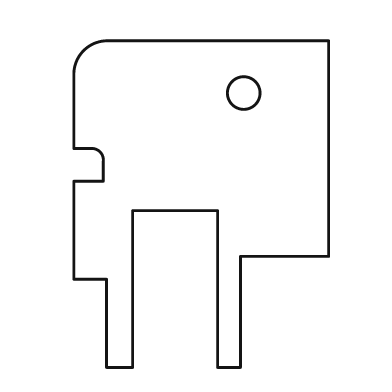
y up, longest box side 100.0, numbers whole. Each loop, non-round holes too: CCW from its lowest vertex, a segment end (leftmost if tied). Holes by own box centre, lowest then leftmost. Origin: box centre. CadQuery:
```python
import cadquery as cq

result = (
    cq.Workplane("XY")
    .moveTo(-29.0, -50.0)
    .lineTo(-21.0, -50.0)
    .lineTo(-21.0, -2.0)
    .lineTo(5.0, -2.0)
    .lineTo(5.0, -50.0)
    .lineTo(12.0, -50.0)
    .lineTo(12.0, -16.0)
    .lineTo(39.0, -16.0)
    .lineTo(39.0, 50.0)
    .lineTo(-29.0, 50.0)
    .threePointArc((-36.0, 47.0), (-39.0, 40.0))
    .lineTo(-39.0, 17.0)
    .lineTo(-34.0, 17.0)
    .threePointArc((-31.0, 16.0), (-30.0, 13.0))
    .lineTo(-30.0, 7.0)
    .lineTo(-39.0, 7.0)
    .lineTo(-39.0, -23.0)
    .lineTo(-29.0, -23.0)
    .close()
    .moveTo(13.0, 34.0)
    .circle(5.0)
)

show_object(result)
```